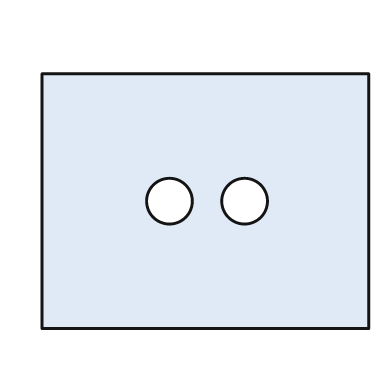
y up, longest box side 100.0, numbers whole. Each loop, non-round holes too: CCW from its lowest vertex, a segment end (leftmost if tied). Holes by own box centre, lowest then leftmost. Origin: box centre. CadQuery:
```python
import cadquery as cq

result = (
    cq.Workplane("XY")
    .moveTo(-50.0, -39.0)
    .lineTo(50.0, -39.0)
    .lineTo(50.0, 39.0)
    .lineTo(-50.0, 39.0)
    .close()
    .moveTo(-11.0, 0.0)
    .circle(7.0)
    .moveTo(12.0, 0.0)
    .circle(7.0)
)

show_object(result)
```